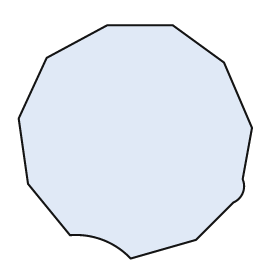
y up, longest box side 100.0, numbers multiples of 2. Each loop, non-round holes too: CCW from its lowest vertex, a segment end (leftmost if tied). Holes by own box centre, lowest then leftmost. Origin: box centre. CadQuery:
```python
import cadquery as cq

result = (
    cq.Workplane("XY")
    .moveTo(-2.0, -50.0)
    .lineTo(26.0, -42.0)
    .lineTo(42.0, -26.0)
    .threePointArc((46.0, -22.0), (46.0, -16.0))
    .lineTo(50.0, 6.0)
    .lineTo(38.0, 34.0)
    .lineTo(16.0, 50.0)
    .lineTo(-12.0, 50.0)
    .lineTo(-38.0, 36.0)
    .lineTo(-50.0, 10.0)
    .lineTo(-46.0, -18.0)
    .lineTo(-28.0, -40.0)
    .threePointArc((-14.0, -42.0), (-2.0, -50.0))
    .close()
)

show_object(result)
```